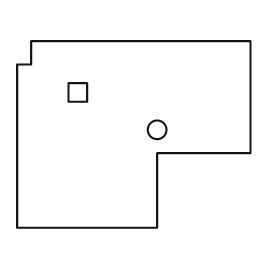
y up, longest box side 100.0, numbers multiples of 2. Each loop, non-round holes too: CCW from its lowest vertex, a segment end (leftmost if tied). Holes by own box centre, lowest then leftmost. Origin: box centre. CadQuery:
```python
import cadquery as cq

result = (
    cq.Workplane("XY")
    .moveTo(-50.0, -40.0)
    .lineTo(10.0, -40.0)
    .lineTo(10.0, -8.0)
    .lineTo(50.0, -8.0)
    .lineTo(50.0, 40.0)
    .lineTo(-44.0, 40.0)
    .lineTo(-44.0, 30.0)
    .lineTo(-50.0, 30.0)
    .close()
    .moveTo(10.0, 2.0)
    .circle(4.0)
    .moveTo(-28.0, 14.0)
    .lineTo(-20.0, 14.0)
    .lineTo(-20.0, 22.0)
    .lineTo(-28.0, 22.0)
    .close()
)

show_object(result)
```